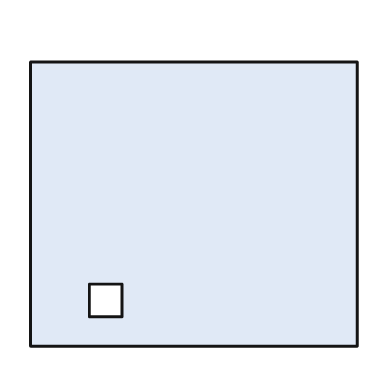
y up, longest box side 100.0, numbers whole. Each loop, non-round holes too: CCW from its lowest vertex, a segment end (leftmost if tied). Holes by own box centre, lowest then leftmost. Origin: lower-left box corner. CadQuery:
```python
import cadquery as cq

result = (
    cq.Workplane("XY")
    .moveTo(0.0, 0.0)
    .lineTo(100.0, 0.0)
    .lineTo(100.0, 87.0)
    .lineTo(0.0, 87.0)
    .close()
    .moveTo(18.0, 9.0)
    .lineTo(28.0, 9.0)
    .lineTo(28.0, 19.0)
    .lineTo(18.0, 19.0)
    .close()
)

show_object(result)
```